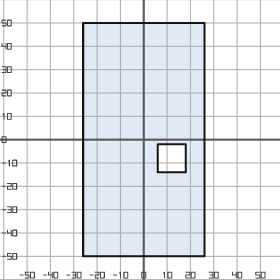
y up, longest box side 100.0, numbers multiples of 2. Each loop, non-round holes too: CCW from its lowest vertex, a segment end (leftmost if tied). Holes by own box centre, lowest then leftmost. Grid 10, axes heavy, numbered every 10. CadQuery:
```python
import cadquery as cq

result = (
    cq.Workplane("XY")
    .moveTo(-26.0, -50.0)
    .lineTo(26.0, -50.0)
    .lineTo(26.0, 50.0)
    .lineTo(-26.0, 50.0)
    .close()
    .moveTo(6.0, -14.0)
    .lineTo(18.0, -14.0)
    .lineTo(18.0, -2.0)
    .lineTo(6.0, -2.0)
    .close()
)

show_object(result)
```